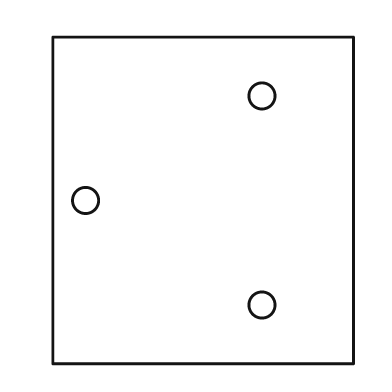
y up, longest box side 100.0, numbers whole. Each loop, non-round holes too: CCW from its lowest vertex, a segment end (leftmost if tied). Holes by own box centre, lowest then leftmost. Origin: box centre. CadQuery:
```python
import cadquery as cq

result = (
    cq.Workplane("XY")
    .moveTo(-46.0, -50.0)
    .lineTo(46.0, -50.0)
    .lineTo(46.0, 50.0)
    .lineTo(-46.0, 50.0)
    .close()
    .moveTo(18.0, -32.0)
    .circle(4.0)
    .moveTo(-36.0, 0.0)
    .circle(4.0)
    .moveTo(18.0, 32.0)
    .circle(4.0)
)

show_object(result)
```